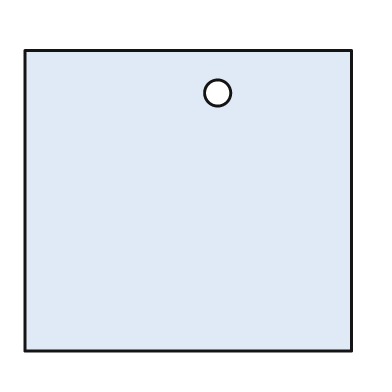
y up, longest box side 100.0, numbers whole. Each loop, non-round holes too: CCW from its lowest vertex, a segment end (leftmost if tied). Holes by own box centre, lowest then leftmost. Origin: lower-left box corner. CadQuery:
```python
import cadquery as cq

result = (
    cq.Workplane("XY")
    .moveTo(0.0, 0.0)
    .lineTo(100.0, 0.0)
    .lineTo(100.0, 92.0)
    .lineTo(0.0, 92.0)
    .close()
    .moveTo(59.0, 79.0)
    .circle(4.0)
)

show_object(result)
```